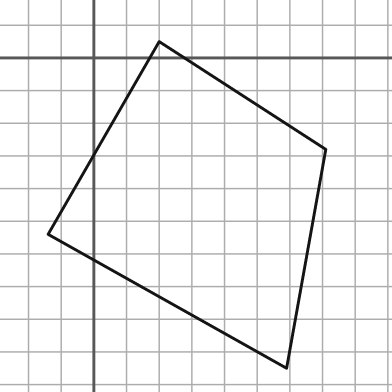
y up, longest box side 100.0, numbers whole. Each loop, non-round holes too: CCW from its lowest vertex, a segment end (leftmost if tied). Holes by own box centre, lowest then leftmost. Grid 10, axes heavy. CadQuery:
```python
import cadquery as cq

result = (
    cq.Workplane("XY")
    .moveTo(59.0, -95.0)
    .lineTo(71.0, -28.0)
    .lineTo(20.0, 5.0)
    .lineTo(-14.0, -54.0)
    .close()
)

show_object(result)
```